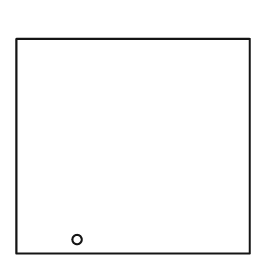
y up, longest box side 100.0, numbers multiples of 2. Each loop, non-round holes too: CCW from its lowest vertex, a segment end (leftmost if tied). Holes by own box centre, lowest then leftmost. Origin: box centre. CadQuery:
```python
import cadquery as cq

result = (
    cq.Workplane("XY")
    .moveTo(-50.0, -46.0)
    .lineTo(50.0, -46.0)
    .lineTo(50.0, 46.0)
    .lineTo(-50.0, 46.0)
    .close()
    .moveTo(-24.0, -40.0)
    .circle(2.0)
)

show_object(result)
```